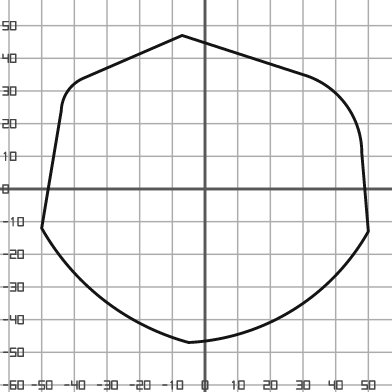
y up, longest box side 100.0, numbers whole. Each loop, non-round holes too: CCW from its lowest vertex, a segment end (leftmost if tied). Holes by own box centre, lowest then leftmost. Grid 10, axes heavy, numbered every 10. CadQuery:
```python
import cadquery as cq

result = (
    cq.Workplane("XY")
    .moveTo(-5.0, -47.0)
    .threePointArc((27.0, -37.0), (50.0, -13.0))
    .lineTo(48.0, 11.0)
    .threePointArc((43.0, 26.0), (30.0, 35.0))
    .lineTo(-7.0, 47.0)
    .lineTo(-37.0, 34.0)
    .threePointArc((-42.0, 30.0), (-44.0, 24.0))
    .lineTo(-50.0, -12.0)
    .threePointArc((-31.0, -34.0), (-5.0, -47.0))
    .close()
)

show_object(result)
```